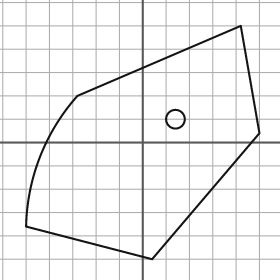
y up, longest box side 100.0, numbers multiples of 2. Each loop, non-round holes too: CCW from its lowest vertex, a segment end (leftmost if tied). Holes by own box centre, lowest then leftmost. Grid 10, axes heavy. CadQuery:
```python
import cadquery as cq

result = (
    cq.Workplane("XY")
    .moveTo(4.0, -50.0)
    .lineTo(50.0, 4.0)
    .lineTo(42.0, 50.0)
    .lineTo(-28.0, 20.0)
    .threePointArc((-44.0, -6.0), (-50.0, -36.0))
    .close()
    .moveTo(14.0, 10.0)
    .circle(4.0)
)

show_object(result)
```